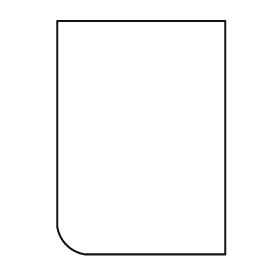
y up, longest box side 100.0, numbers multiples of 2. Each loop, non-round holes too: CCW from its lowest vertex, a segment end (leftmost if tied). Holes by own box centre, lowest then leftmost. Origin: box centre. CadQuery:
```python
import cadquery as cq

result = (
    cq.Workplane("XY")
    .moveTo(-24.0, -50.0)
    .lineTo(36.0, -50.0)
    .lineTo(36.0, 50.0)
    .lineTo(-36.0, 50.0)
    .lineTo(-36.0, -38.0)
    .threePointArc((-32.0, -46.0), (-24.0, -50.0))
    .close()
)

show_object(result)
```